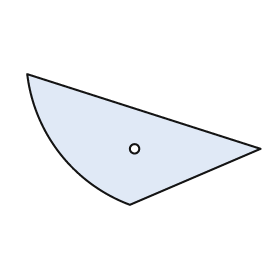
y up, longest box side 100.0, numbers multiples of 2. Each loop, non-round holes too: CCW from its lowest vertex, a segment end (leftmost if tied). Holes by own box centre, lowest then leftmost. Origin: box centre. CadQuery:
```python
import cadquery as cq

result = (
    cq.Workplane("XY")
    .moveTo(-6.0, -28.0)
    .lineTo(50.0, -4.0)
    .lineTo(-50.0, 28.0)
    .threePointArc((-36.0, -6.0), (-6.0, -28.0))
    .close()
    .moveTo(-4.0, -4.0)
    .circle(2.0)
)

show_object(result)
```